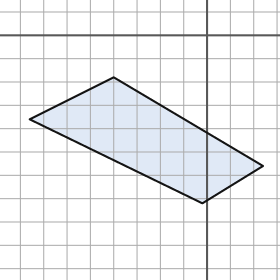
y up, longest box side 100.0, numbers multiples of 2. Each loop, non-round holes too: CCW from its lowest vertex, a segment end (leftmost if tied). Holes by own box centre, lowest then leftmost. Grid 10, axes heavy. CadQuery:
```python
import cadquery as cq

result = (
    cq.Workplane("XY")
    .moveTo(-2.0, -72.0)
    .lineTo(24.0, -56.0)
    .lineTo(-40.0, -18.0)
    .lineTo(-76.0, -36.0)
    .close()
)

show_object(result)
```